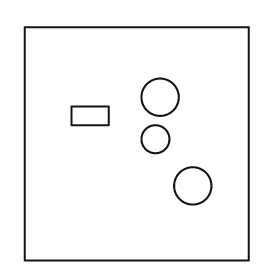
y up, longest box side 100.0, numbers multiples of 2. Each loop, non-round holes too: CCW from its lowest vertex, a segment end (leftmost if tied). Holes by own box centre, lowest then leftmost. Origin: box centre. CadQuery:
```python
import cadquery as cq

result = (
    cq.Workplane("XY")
    .moveTo(-48.0, -50.0)
    .lineTo(48.0, -50.0)
    .lineTo(48.0, 50.0)
    .lineTo(-48.0, 50.0)
    .close()
    .moveTo(24.0, -18.0)
    .circle(8.0)
    .moveTo(8.0, 2.0)
    .circle(6.0)
    .moveTo(-28.0, 8.0)
    .lineTo(-12.0, 8.0)
    .lineTo(-12.0, 16.0)
    .lineTo(-28.0, 16.0)
    .close()
    .moveTo(10.0, 20.0)
    .circle(8.0)
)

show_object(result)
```